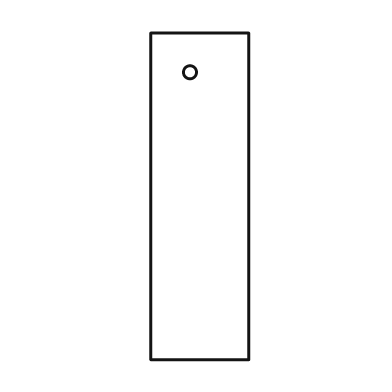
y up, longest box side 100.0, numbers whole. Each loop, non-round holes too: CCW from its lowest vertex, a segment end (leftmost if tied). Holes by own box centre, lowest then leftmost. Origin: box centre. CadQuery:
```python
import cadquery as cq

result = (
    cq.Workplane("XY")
    .moveTo(-15.0, -50.0)
    .lineTo(15.0, -50.0)
    .lineTo(15.0, 50.0)
    .lineTo(-15.0, 50.0)
    .close()
    .moveTo(-3.0, 38.0)
    .circle(2.0)
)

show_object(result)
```